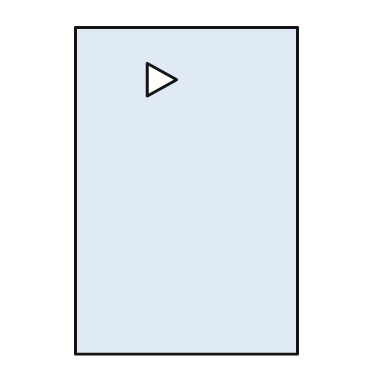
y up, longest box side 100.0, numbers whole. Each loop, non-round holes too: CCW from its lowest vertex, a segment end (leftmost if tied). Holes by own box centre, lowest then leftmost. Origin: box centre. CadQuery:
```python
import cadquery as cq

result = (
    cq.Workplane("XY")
    .moveTo(-34.0, -50.0)
    .lineTo(34.0, -50.0)
    .lineTo(34.0, 50.0)
    .lineTo(-34.0, 50.0)
    .close()
    .moveTo(-12.0, 29.0)
    .lineTo(-3.0, 34.0)
    .lineTo(-12.0, 39.0)
    .close()
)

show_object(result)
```